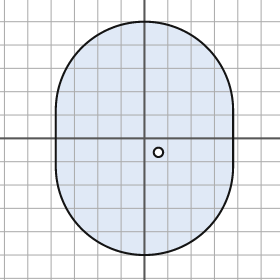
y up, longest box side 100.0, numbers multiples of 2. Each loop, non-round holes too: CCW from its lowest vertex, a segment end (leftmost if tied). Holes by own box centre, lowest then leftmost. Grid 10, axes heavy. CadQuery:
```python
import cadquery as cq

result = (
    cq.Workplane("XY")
    .moveTo(-38.0, -12.0)
    .threePointArc((0.0, -50.0), (38.0, -12.0))
    .lineTo(38.0, 12.0)
    .threePointArc((0.0, 50.0), (-38.0, 12.0))
    .close()
    .moveTo(6.0, -6.0)
    .circle(2.0)
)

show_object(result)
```